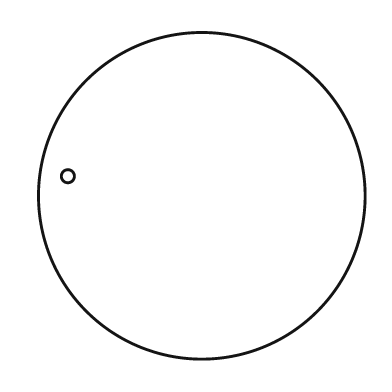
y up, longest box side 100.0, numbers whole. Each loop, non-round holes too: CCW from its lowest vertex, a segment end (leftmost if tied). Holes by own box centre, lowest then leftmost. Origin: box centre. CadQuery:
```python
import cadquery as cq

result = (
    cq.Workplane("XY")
    .moveTo(0.0, 0.0)
    .circle(50.0)
    .moveTo(-41.0, 6.0)
    .circle(2.0)
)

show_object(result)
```